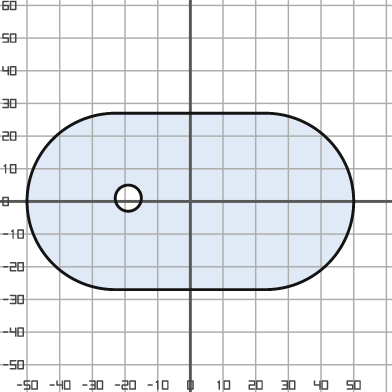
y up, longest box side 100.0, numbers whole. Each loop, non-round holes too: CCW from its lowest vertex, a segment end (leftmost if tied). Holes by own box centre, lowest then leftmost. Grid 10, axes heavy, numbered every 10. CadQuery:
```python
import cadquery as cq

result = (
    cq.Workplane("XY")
    .moveTo(-23.0, -27.0)
    .lineTo(23.0, -27.0)
    .threePointArc((50.0, 0.0), (23.0, 27.0))
    .lineTo(-23.0, 27.0)
    .threePointArc((-50.0, 0.0), (-23.0, -27.0))
    .close()
    .moveTo(-19.0, 1.0)
    .circle(4.0)
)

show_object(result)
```